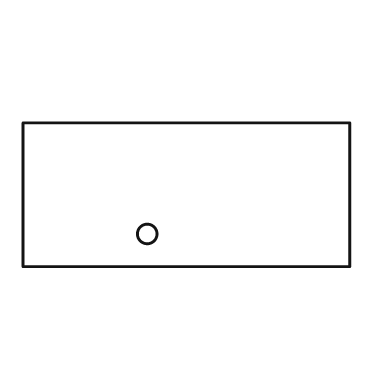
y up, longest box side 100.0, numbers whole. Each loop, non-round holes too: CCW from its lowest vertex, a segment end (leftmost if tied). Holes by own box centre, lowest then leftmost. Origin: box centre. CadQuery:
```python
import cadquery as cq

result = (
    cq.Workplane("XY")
    .moveTo(-50.0, -22.0)
    .lineTo(50.0, -22.0)
    .lineTo(50.0, 22.0)
    .lineTo(-50.0, 22.0)
    .close()
    .moveTo(-12.0, -12.0)
    .circle(3.0)
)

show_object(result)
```